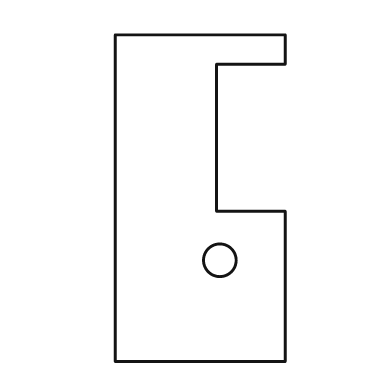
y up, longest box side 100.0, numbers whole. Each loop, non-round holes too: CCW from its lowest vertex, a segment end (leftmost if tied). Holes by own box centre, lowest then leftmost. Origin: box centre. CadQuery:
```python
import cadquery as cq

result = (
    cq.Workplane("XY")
    .moveTo(-26.0, -50.0)
    .lineTo(26.0, -50.0)
    .lineTo(26.0, -4.0)
    .lineTo(5.0, -4.0)
    .lineTo(5.0, 41.0)
    .lineTo(26.0, 41.0)
    .lineTo(26.0, 50.0)
    .lineTo(-26.0, 50.0)
    .close()
    .moveTo(6.0, -19.0)
    .circle(5.0)
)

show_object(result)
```